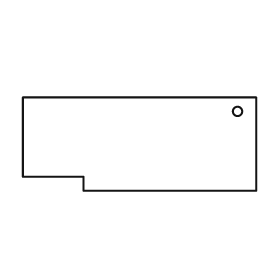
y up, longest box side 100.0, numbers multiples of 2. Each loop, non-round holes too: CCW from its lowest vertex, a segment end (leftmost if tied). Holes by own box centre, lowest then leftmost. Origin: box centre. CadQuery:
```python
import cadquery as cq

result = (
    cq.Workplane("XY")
    .moveTo(-24.0, -20.0)
    .lineTo(50.0, -20.0)
    .lineTo(50.0, 20.0)
    .lineTo(-50.0, 20.0)
    .lineTo(-50.0, -14.0)
    .lineTo(-24.0, -14.0)
    .close()
    .moveTo(42.0, 14.0)
    .circle(2.0)
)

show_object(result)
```